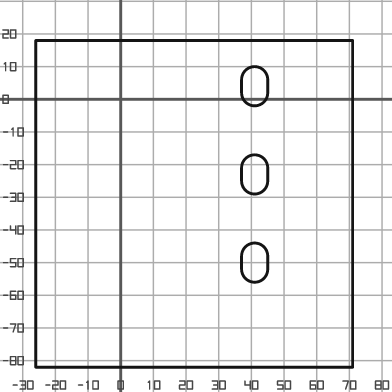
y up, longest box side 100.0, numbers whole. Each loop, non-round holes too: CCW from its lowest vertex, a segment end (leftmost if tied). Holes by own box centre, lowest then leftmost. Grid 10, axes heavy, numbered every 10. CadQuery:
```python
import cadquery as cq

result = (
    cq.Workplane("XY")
    .moveTo(-26.0, -82.0)
    .lineTo(71.0, -82.0)
    .lineTo(71.0, 18.0)
    .lineTo(-26.0, 18.0)
    .close()
    .moveTo(37.0, -52.0)
    .threePointArc((41.0, -56.0), (45.0, -52.0))
    .lineTo(45.0, -48.0)
    .threePointArc((41.0, -44.0), (37.0, -48.0))
    .close()
    .moveTo(37.0, -25.0)
    .threePointArc((41.0, -29.0), (45.0, -25.0))
    .lineTo(45.0, -21.0)
    .threePointArc((41.0, -17.0), (37.0, -21.0))
    .close()
    .moveTo(37.0, 2.0)
    .threePointArc((41.0, -2.0), (45.0, 2.0))
    .lineTo(45.0, 6.0)
    .threePointArc((41.0, 10.0), (37.0, 6.0))
    .close()
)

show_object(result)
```